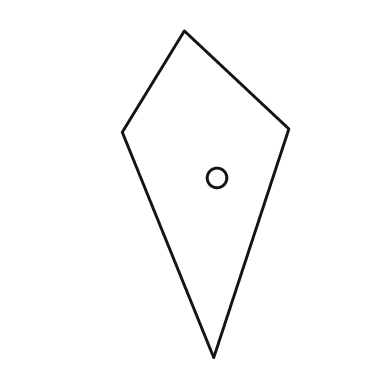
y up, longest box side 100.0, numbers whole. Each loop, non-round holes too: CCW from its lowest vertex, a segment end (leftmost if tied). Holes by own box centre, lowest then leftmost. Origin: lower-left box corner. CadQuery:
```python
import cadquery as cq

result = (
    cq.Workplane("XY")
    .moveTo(28.0, 0.0)
    .lineTo(51.0, 70.0)
    .lineTo(19.0, 100.0)
    .lineTo(0.0, 69.0)
    .close()
    .moveTo(29.0, 55.0)
    .circle(3.0)
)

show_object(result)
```